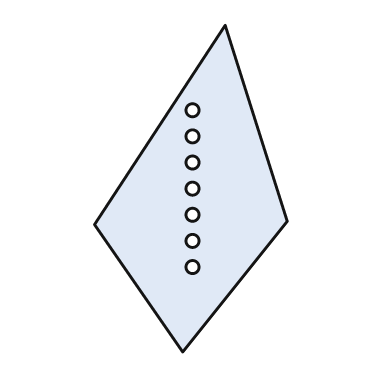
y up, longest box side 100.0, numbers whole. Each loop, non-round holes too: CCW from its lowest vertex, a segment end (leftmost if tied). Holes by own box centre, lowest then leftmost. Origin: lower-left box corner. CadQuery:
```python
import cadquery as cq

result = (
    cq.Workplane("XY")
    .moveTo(27.0, 0.0)
    .lineTo(59.0, 40.0)
    .lineTo(40.0, 100.0)
    .lineTo(0.0, 39.0)
    .close()
    .moveTo(30.0, 26.0)
    .circle(2.0)
    .moveTo(30.0, 34.0)
    .circle(2.0)
    .moveTo(30.0, 42.0)
    .circle(2.0)
    .moveTo(30.0, 50.0)
    .circle(2.0)
    .moveTo(30.0, 58.0)
    .circle(2.0)
    .moveTo(30.0, 66.0)
    .circle(2.0)
    .moveTo(30.0, 74.0)
    .circle(2.0)
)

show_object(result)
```